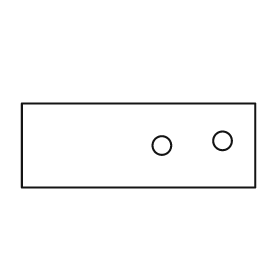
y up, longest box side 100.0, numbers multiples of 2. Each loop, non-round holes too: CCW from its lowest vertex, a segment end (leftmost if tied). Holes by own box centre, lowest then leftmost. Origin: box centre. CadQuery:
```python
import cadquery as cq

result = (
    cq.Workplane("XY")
    .moveTo(-50.0, -18.0)
    .lineTo(50.0, -18.0)
    .lineTo(50.0, 18.0)
    .lineTo(-50.0, 18.0)
    .close()
    .moveTo(10.0, 0.0)
    .circle(4.0)
    .moveTo(36.0, 2.0)
    .circle(4.0)
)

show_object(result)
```